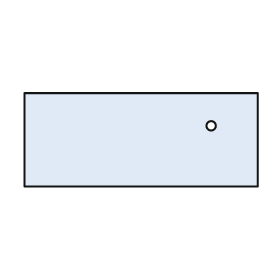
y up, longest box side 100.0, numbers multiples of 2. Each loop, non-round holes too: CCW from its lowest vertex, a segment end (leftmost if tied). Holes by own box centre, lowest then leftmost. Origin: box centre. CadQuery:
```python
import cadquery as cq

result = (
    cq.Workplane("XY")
    .moveTo(-50.0, -20.0)
    .lineTo(50.0, -20.0)
    .lineTo(50.0, 20.0)
    .lineTo(-50.0, 20.0)
    .close()
    .moveTo(30.0, 6.0)
    .circle(2.0)
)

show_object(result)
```